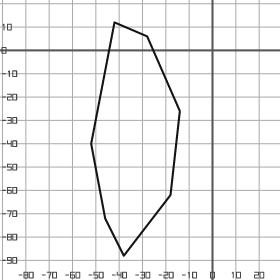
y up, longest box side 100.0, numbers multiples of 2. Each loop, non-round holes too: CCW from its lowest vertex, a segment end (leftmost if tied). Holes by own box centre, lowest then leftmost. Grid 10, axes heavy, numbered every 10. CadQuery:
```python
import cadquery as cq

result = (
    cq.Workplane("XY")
    .moveTo(-38.0, -88.0)
    .lineTo(-18.0, -62.0)
    .lineTo(-14.0, -26.0)
    .lineTo(-28.0, 6.0)
    .lineTo(-42.0, 12.0)
    .lineTo(-52.0, -40.0)
    .lineTo(-46.0, -72.0)
    .close()
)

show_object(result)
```